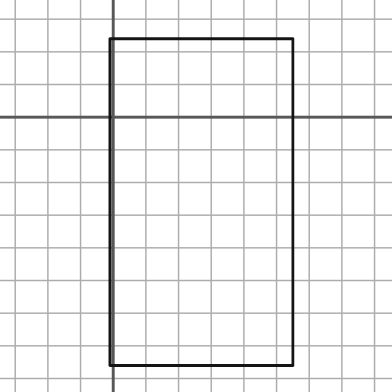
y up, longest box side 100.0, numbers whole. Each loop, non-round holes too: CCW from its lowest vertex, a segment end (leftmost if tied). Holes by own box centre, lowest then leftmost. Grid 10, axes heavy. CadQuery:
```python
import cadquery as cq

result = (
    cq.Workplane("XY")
    .moveTo(-1.0, -76.0)
    .lineTo(55.0, -76.0)
    .lineTo(55.0, 24.0)
    .lineTo(-1.0, 24.0)
    .close()
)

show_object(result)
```